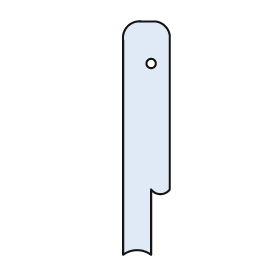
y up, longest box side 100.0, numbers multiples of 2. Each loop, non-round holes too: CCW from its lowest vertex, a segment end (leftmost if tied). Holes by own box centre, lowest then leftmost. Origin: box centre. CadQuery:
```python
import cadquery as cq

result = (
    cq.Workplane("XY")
    .moveTo(-10.0, -50.0)
    .threePointArc((-4.0, -48.0), (2.0, -50.0))
    .lineTo(2.0, -22.0)
    .threePointArc((6.0, -24.0), (10.0, -22.0))
    .lineTo(10.0, 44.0)
    .threePointArc((8.0, 48.0), (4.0, 50.0))
    .lineTo(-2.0, 50.0)
    .threePointArc((-8.0, 48.0), (-10.0, 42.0))
    .close()
    .moveTo(2.0, 32.0)
    .circle(2.0)
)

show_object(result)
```